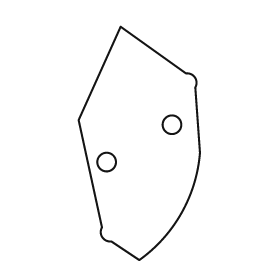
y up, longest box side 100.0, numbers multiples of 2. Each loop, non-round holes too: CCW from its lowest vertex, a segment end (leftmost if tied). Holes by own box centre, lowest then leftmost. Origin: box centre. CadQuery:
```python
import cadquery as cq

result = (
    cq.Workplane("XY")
    .moveTo(0.0, -50.0)
    .threePointArc((18.0, -30.0), (26.0, -4.0))
    .lineTo(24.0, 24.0)
    .threePointArc((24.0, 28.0), (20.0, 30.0))
    .lineTo(-8.0, 50.0)
    .lineTo(-26.0, 10.0)
    .lineTo(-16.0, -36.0)
    .threePointArc((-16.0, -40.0), (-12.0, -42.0))
    .close()
    .moveTo(-14.0, -8.0)
    .circle(4.0)
    .moveTo(14.0, 8.0)
    .circle(4.0)
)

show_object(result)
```